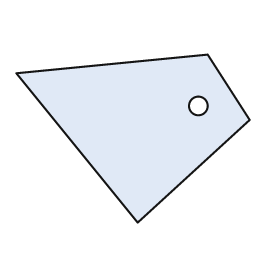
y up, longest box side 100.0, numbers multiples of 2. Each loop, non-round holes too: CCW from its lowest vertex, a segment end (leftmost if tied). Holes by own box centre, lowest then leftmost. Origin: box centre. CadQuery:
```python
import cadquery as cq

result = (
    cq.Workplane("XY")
    .moveTo(2.0, -36.0)
    .lineTo(50.0, 8.0)
    .lineTo(32.0, 36.0)
    .lineTo(-50.0, 28.0)
    .close()
    .moveTo(28.0, 14.0)
    .circle(4.0)
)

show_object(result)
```